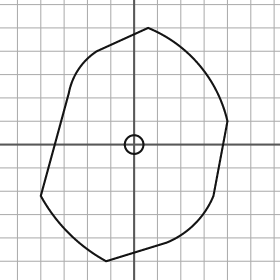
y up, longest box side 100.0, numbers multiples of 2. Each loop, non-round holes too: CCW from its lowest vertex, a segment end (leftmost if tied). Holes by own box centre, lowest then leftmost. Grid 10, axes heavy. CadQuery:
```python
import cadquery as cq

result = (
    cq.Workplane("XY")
    .moveTo(-12.0, -50.0)
    .lineTo(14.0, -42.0)
    .threePointArc((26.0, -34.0), (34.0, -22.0))
    .lineTo(40.0, 10.0)
    .threePointArc((28.0, 34.0), (6.0, 50.0))
    .lineTo(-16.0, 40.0)
    .threePointArc((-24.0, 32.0), (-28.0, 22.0))
    .lineTo(-40.0, -22.0)
    .threePointArc((-28.0, -38.0), (-12.0, -50.0))
    .close()
    .moveTo(0.0, 0.0)
    .circle(4.0)
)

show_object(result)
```